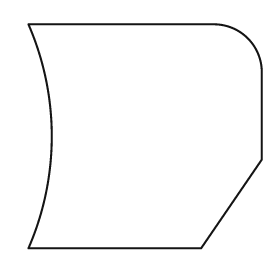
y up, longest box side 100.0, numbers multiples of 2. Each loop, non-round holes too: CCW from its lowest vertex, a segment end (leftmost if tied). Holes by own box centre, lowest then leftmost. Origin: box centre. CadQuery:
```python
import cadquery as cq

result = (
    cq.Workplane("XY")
    .moveTo(-50.0, -48.0)
    .lineTo(24.0, -48.0)
    .lineTo(50.0, -10.0)
    .lineTo(50.0, 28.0)
    .threePointArc((44.0, 42.0), (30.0, 48.0))
    .lineTo(-50.0, 48.0)
    .threePointArc((-40.0, 0.0), (-50.0, -48.0))
    .close()
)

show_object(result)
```